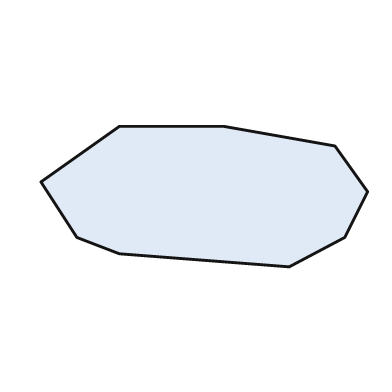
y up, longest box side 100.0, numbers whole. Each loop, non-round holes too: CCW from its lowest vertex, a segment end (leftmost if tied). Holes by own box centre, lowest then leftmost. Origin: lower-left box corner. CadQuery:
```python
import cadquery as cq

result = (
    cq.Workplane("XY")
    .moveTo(76.0, 0.0)
    .lineTo(93.0, 9.0)
    .lineTo(100.0, 23.0)
    .lineTo(90.0, 37.0)
    .lineTo(56.0, 43.0)
    .lineTo(24.0, 43.0)
    .lineTo(0.0, 26.0)
    .lineTo(11.0, 9.0)
    .lineTo(24.0, 4.0)
    .close()
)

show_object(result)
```